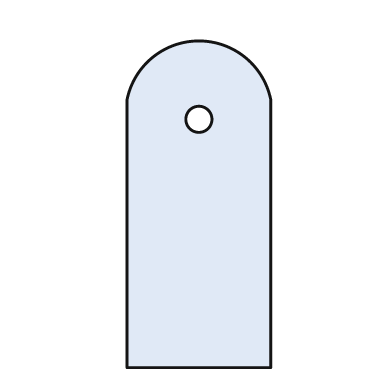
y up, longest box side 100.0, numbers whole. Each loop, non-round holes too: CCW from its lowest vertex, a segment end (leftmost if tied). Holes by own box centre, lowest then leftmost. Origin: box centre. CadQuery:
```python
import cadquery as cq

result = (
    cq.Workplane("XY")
    .moveTo(-22.0, -50.0)
    .lineTo(22.0, -50.0)
    .lineTo(22.0, 32.0)
    .threePointArc((0.0, 50.0), (-22.0, 32.0))
    .close()
    .moveTo(0.0, 26.0)
    .circle(4.0)
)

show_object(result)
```